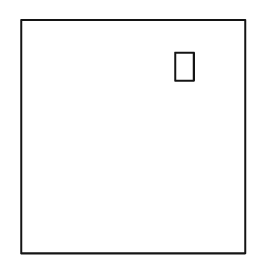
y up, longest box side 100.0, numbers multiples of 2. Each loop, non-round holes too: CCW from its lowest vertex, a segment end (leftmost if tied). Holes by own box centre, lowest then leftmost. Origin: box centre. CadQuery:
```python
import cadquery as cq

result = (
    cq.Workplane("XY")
    .moveTo(-48.0, -50.0)
    .lineTo(48.0, -50.0)
    .lineTo(48.0, 50.0)
    .lineTo(-48.0, 50.0)
    .close()
    .moveTo(18.0, 24.0)
    .lineTo(26.0, 24.0)
    .lineTo(26.0, 36.0)
    .lineTo(18.0, 36.0)
    .close()
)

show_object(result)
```